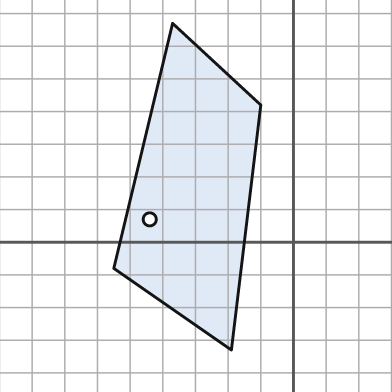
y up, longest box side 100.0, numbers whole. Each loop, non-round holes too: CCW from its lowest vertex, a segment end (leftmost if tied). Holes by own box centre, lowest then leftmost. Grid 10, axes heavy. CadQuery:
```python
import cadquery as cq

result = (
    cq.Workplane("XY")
    .moveTo(-19.0, -33.0)
    .lineTo(-10.0, 42.0)
    .lineTo(-37.0, 67.0)
    .lineTo(-55.0, -8.0)
    .close()
    .moveTo(-44.0, 7.0)
    .circle(2.0)
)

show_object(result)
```